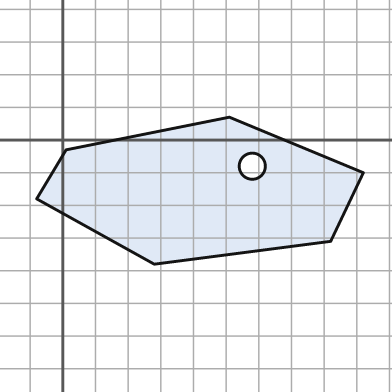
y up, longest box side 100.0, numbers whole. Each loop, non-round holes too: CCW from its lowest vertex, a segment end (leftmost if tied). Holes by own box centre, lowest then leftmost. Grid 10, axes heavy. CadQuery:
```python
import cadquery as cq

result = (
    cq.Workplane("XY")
    .moveTo(28.0, -38.0)
    .lineTo(82.0, -31.0)
    .lineTo(92.0, -10.0)
    .lineTo(51.0, 7.0)
    .lineTo(1.0, -3.0)
    .lineTo(-8.0, -18.0)
    .close()
    .moveTo(58.0, -8.0)
    .circle(4.0)
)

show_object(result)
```